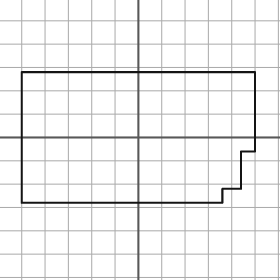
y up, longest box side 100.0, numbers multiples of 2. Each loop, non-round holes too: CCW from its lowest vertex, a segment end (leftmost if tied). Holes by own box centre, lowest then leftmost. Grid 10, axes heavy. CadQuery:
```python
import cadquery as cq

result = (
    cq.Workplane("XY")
    .moveTo(-50.0, -28.0)
    .lineTo(36.0, -28.0)
    .lineTo(36.0, -22.0)
    .lineTo(44.0, -22.0)
    .lineTo(44.0, -6.0)
    .lineTo(50.0, -6.0)
    .lineTo(50.0, 28.0)
    .lineTo(-50.0, 28.0)
    .close()
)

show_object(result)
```